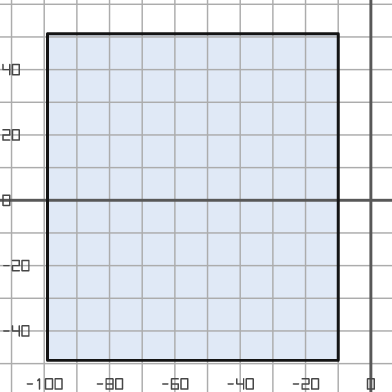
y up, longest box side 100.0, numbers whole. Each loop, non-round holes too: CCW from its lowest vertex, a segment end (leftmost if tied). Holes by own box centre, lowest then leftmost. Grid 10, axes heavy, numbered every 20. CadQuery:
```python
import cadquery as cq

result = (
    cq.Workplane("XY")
    .moveTo(-99.0, -49.0)
    .lineTo(-10.0, -49.0)
    .lineTo(-10.0, 51.0)
    .lineTo(-99.0, 51.0)
    .close()
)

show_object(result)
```